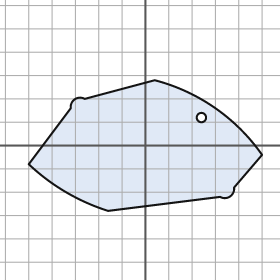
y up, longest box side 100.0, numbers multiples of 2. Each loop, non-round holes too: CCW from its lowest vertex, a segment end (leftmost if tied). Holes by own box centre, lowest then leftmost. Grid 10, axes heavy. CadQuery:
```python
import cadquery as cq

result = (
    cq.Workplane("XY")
    .moveTo(-16.0, -28.0)
    .lineTo(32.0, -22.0)
    .threePointArc((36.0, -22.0), (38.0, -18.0))
    .lineTo(50.0, -4.0)
    .threePointArc((30.0, 16.0), (4.0, 28.0))
    .lineTo(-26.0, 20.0)
    .threePointArc((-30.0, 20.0), (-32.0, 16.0))
    .lineTo(-50.0, -8.0)
    .threePointArc((-34.0, -20.0), (-16.0, -28.0))
    .close()
    .moveTo(24.0, 12.0)
    .circle(2.0)
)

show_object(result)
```